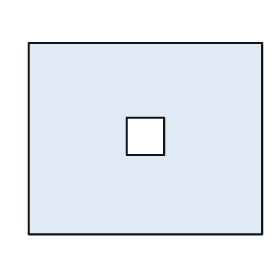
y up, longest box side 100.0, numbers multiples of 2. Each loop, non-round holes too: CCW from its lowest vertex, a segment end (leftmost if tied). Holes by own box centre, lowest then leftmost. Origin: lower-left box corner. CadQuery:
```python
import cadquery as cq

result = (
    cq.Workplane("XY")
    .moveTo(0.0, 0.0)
    .lineTo(100.0, 0.0)
    .lineTo(100.0, 82.0)
    .lineTo(0.0, 82.0)
    .close()
    .moveTo(42.0, 34.0)
    .lineTo(58.0, 34.0)
    .lineTo(58.0, 50.0)
    .lineTo(42.0, 50.0)
    .close()
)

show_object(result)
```